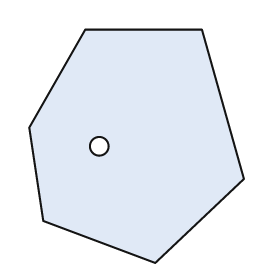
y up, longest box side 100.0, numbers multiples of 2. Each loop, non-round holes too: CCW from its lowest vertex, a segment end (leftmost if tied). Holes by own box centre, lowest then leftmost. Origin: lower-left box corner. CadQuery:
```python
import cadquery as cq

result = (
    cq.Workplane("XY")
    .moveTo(54.0, 0.0)
    .lineTo(92.0, 36.0)
    .lineTo(74.0, 100.0)
    .lineTo(24.0, 100.0)
    .lineTo(0.0, 58.0)
    .lineTo(6.0, 18.0)
    .close()
    .moveTo(30.0, 50.0)
    .circle(4.0)
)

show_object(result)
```